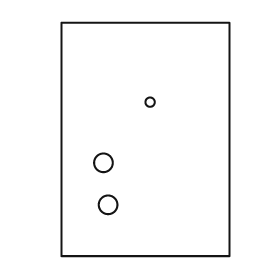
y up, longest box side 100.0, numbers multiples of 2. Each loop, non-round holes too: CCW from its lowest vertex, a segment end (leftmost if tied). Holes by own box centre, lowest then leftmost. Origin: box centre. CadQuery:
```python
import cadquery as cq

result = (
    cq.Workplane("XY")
    .moveTo(-36.0, -50.0)
    .lineTo(36.0, -50.0)
    .lineTo(36.0, 50.0)
    .lineTo(-36.0, 50.0)
    .close()
    .moveTo(-16.0, -28.0)
    .circle(4.0)
    .moveTo(-18.0, -10.0)
    .circle(4.0)
    .moveTo(2.0, 16.0)
    .circle(2.0)
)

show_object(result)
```